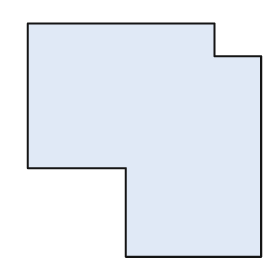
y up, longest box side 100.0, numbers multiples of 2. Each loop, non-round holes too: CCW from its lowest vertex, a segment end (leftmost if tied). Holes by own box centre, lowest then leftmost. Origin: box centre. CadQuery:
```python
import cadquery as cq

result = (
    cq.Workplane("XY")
    .moveTo(-8.0, -50.0)
    .lineTo(50.0, -50.0)
    .lineTo(50.0, 36.0)
    .lineTo(30.0, 36.0)
    .lineTo(30.0, 50.0)
    .lineTo(-50.0, 50.0)
    .lineTo(-50.0, -12.0)
    .lineTo(-8.0, -12.0)
    .close()
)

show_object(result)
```